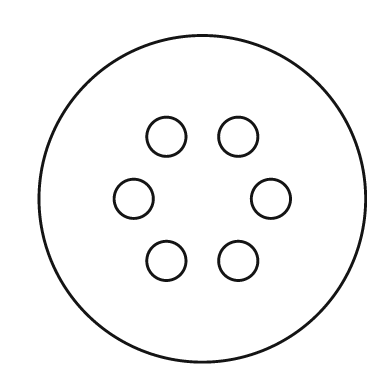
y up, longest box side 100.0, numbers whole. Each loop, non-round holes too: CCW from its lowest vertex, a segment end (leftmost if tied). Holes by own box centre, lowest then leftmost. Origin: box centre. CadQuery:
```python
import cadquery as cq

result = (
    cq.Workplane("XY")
    .moveTo(0.0, 0.0)
    .circle(50.0)
    .moveTo(-11.0, -19.0)
    .circle(6.0)
    .moveTo(11.0, -19.0)
    .circle(6.0)
    .moveTo(-21.0, 0.0)
    .circle(6.0)
    .moveTo(21.0, 0.0)
    .circle(6.0)
    .moveTo(-11.0, 19.0)
    .circle(6.0)
    .moveTo(11.0, 19.0)
    .circle(6.0)
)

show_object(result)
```